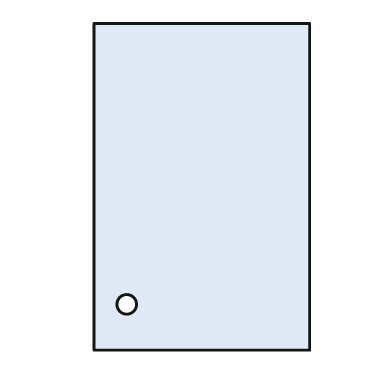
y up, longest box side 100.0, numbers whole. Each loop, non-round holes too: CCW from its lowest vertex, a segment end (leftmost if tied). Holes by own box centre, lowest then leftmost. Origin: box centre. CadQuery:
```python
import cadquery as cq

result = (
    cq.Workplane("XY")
    .moveTo(-33.0, -50.0)
    .lineTo(33.0, -50.0)
    .lineTo(33.0, 50.0)
    .lineTo(-33.0, 50.0)
    .close()
    .moveTo(-23.0, -36.0)
    .circle(3.0)
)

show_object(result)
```